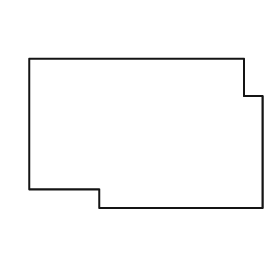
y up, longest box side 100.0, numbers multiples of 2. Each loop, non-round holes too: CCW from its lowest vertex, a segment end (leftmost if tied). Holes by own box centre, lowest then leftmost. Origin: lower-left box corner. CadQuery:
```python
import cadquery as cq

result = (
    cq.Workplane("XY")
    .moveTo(30.0, 0.0)
    .lineTo(100.0, 0.0)
    .lineTo(100.0, 48.0)
    .lineTo(92.0, 48.0)
    .lineTo(92.0, 64.0)
    .lineTo(0.0, 64.0)
    .lineTo(0.0, 8.0)
    .lineTo(30.0, 8.0)
    .close()
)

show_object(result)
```